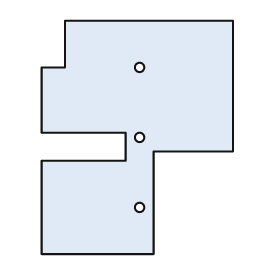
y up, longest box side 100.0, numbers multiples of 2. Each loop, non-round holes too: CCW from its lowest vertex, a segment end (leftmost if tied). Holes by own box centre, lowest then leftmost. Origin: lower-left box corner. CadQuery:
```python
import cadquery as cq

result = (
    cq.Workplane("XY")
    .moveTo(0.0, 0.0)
    .lineTo(48.0, 0.0)
    .lineTo(48.0, 44.0)
    .lineTo(82.0, 44.0)
    .lineTo(82.0, 100.0)
    .lineTo(10.0, 100.0)
    .lineTo(10.0, 80.0)
    .lineTo(0.0, 80.0)
    .lineTo(0.0, 52.0)
    .lineTo(36.0, 52.0)
    .lineTo(36.0, 40.0)
    .lineTo(0.0, 40.0)
    .close()
    .moveTo(42.0, 20.0)
    .circle(2.0)
    .moveTo(42.0, 50.0)
    .circle(2.0)
    .moveTo(42.0, 80.0)
    .circle(2.0)
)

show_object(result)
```